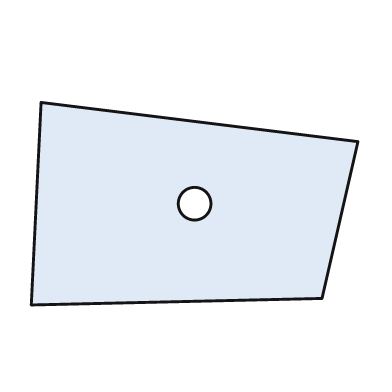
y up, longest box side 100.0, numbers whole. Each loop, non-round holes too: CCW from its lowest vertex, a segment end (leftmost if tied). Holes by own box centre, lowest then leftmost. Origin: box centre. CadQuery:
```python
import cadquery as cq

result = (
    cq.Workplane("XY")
    .moveTo(-50.0, -31.0)
    .lineTo(39.0, -29.0)
    .lineTo(50.0, 19.0)
    .lineTo(-47.0, 31.0)
    .close()
    .moveTo(0.0, 0.0)
    .circle(5.0)
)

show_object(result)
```